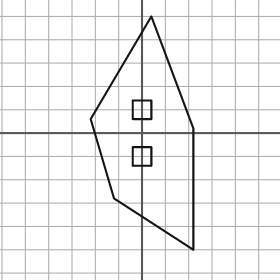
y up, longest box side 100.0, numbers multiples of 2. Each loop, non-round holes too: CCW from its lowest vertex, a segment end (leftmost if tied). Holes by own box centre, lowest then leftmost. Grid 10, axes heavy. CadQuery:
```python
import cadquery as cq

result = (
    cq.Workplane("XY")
    .moveTo(22.0, -50.0)
    .lineTo(22.0, 2.0)
    .lineTo(4.0, 50.0)
    .lineTo(-22.0, 6.0)
    .lineTo(-12.0, -28.0)
    .close()
    .moveTo(-4.0, -14.0)
    .lineTo(4.0, -14.0)
    .lineTo(4.0, -6.0)
    .lineTo(-4.0, -6.0)
    .close()
    .moveTo(-4.0, 6.0)
    .lineTo(4.0, 6.0)
    .lineTo(4.0, 14.0)
    .lineTo(-4.0, 14.0)
    .close()
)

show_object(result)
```